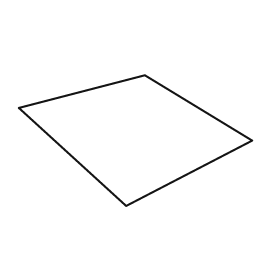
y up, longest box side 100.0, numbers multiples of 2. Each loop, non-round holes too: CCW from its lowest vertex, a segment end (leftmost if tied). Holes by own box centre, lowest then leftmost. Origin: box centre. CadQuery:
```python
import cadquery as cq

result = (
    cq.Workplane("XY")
    .moveTo(-4.0, -28.0)
    .lineTo(50.0, 0.0)
    .lineTo(4.0, 28.0)
    .lineTo(-50.0, 14.0)
    .close()
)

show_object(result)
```